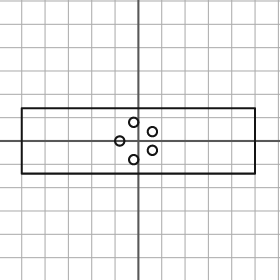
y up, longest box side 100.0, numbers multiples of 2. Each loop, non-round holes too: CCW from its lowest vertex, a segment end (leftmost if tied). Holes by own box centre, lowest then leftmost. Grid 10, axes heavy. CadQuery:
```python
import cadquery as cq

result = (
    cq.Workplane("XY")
    .moveTo(-50.0, -14.0)
    .lineTo(50.0, -14.0)
    .lineTo(50.0, 14.0)
    .lineTo(-50.0, 14.0)
    .close()
    .moveTo(-2.0, -8.0)
    .circle(2.0)
    .moveTo(6.0, -4.0)
    .circle(2.0)
    .moveTo(-8.0, 0.0)
    .circle(2.0)
    .moveTo(6.0, 4.0)
    .circle(2.0)
    .moveTo(-2.0, 8.0)
    .circle(2.0)
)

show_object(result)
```